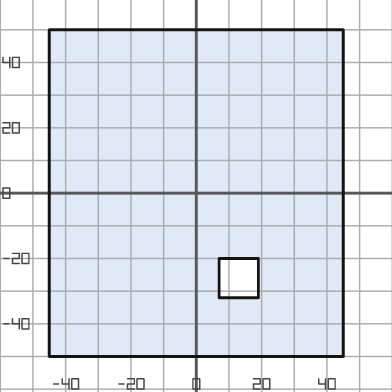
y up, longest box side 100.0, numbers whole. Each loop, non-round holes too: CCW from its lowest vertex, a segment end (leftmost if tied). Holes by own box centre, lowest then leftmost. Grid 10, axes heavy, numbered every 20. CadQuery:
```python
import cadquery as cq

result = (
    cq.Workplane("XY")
    .moveTo(-45.0, -50.0)
    .lineTo(45.0, -50.0)
    .lineTo(45.0, 50.0)
    .lineTo(-45.0, 50.0)
    .close()
    .moveTo(7.0, -32.0)
    .lineTo(19.0, -32.0)
    .lineTo(19.0, -20.0)
    .lineTo(7.0, -20.0)
    .close()
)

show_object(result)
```